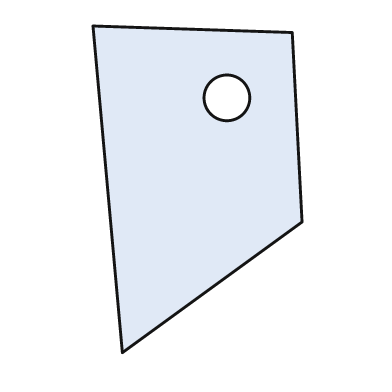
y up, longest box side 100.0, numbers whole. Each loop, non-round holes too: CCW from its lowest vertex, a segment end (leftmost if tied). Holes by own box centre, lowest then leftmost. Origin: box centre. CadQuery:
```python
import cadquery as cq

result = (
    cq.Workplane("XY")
    .moveTo(-23.0, -50.0)
    .lineTo(32.0, -10.0)
    .lineTo(29.0, 48.0)
    .lineTo(-32.0, 50.0)
    .close()
    .moveTo(9.0, 28.0)
    .circle(7.0)
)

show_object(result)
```